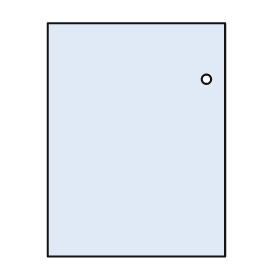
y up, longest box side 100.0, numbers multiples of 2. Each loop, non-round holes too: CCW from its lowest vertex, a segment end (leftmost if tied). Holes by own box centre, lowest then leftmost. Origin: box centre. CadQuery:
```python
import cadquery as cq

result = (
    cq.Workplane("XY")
    .moveTo(-38.0, -50.0)
    .lineTo(38.0, -50.0)
    .lineTo(38.0, 50.0)
    .lineTo(-38.0, 50.0)
    .close()
    .moveTo(30.0, 26.0)
    .circle(2.0)
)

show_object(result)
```